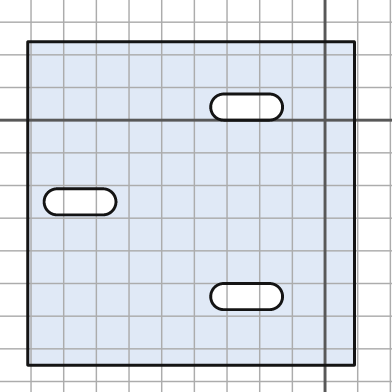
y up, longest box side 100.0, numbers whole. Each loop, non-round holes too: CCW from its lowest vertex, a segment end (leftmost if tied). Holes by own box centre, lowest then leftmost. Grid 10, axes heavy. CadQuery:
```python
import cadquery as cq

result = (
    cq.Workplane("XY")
    .moveTo(-91.0, -75.0)
    .lineTo(9.0, -75.0)
    .lineTo(9.0, 24.0)
    .lineTo(-91.0, 24.0)
    .close()
    .moveTo(-31.0, -58.0)
    .lineTo(-17.0, -58.0)
    .threePointArc((-13.0, -54.0), (-17.0, -50.0))
    .lineTo(-31.0, -50.0)
    .threePointArc((-35.0, -54.0), (-31.0, -58.0))
    .close()
    .moveTo(-82.0, -29.0)
    .lineTo(-68.0, -29.0)
    .threePointArc((-64.0, -25.0), (-68.0, -21.0))
    .lineTo(-82.0, -21.0)
    .threePointArc((-86.0, -25.0), (-82.0, -29.0))
    .close()
    .moveTo(-31.0, 0.0)
    .lineTo(-17.0, 0.0)
    .threePointArc((-13.0, 4.0), (-17.0, 8.0))
    .lineTo(-31.0, 8.0)
    .threePointArc((-35.0, 4.0), (-31.0, 0.0))
    .close()
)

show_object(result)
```